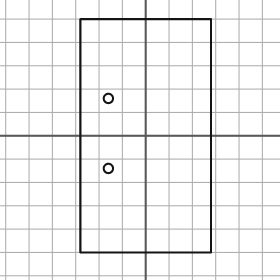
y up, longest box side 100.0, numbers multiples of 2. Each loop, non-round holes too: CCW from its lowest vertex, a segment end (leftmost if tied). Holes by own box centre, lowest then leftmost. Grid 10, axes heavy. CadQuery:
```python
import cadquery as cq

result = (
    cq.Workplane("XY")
    .moveTo(-28.0, -50.0)
    .lineTo(28.0, -50.0)
    .lineTo(28.0, 50.0)
    .lineTo(-28.0, 50.0)
    .close()
    .moveTo(-16.0, -14.0)
    .circle(2.0)
    .moveTo(-16.0, 16.0)
    .circle(2.0)
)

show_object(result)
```